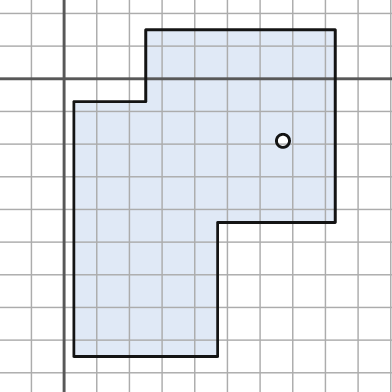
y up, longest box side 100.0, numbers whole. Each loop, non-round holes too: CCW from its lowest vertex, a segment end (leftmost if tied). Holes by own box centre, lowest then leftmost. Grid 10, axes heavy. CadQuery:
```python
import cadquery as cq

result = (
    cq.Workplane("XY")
    .moveTo(3.0, -85.0)
    .lineTo(47.0, -85.0)
    .lineTo(47.0, -44.0)
    .lineTo(83.0, -44.0)
    .lineTo(83.0, 15.0)
    .lineTo(25.0, 15.0)
    .lineTo(25.0, -7.0)
    .lineTo(3.0, -7.0)
    .close()
    .moveTo(67.0, -19.0)
    .circle(2.0)
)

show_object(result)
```